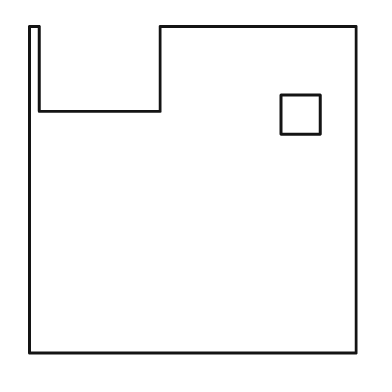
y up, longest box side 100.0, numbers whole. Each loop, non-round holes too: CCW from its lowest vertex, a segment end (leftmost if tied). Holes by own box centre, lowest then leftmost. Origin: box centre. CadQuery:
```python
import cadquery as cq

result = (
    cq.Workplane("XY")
    .moveTo(-50.0, -50.0)
    .lineTo(50.0, -50.0)
    .lineTo(50.0, 50.0)
    .lineTo(-10.0, 50.0)
    .lineTo(-10.0, 24.0)
    .lineTo(-47.0, 24.0)
    .lineTo(-47.0, 50.0)
    .lineTo(-50.0, 50.0)
    .close()
    .moveTo(27.0, 17.0)
    .lineTo(39.0, 17.0)
    .lineTo(39.0, 29.0)
    .lineTo(27.0, 29.0)
    .close()
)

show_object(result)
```